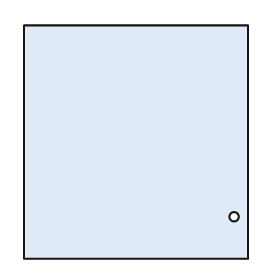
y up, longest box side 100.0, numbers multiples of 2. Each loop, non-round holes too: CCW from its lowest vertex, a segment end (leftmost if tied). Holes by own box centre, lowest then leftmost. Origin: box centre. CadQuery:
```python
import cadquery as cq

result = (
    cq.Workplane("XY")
    .moveTo(-48.0, -50.0)
    .lineTo(48.0, -50.0)
    .lineTo(48.0, 50.0)
    .lineTo(-48.0, 50.0)
    .close()
    .moveTo(42.0, -32.0)
    .circle(2.0)
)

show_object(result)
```